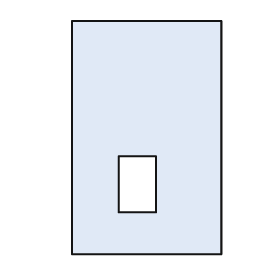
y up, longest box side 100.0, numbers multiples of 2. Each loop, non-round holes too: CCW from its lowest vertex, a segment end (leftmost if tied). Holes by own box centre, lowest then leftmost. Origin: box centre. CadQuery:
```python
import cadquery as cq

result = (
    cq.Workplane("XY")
    .moveTo(-32.0, -50.0)
    .lineTo(32.0, -50.0)
    .lineTo(32.0, 50.0)
    .lineTo(-32.0, 50.0)
    .close()
    .moveTo(-12.0, -32.0)
    .lineTo(4.0, -32.0)
    .lineTo(4.0, -8.0)
    .lineTo(-12.0, -8.0)
    .close()
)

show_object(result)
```